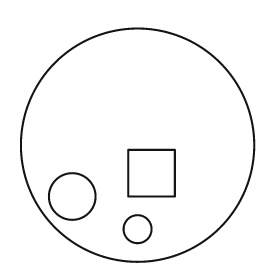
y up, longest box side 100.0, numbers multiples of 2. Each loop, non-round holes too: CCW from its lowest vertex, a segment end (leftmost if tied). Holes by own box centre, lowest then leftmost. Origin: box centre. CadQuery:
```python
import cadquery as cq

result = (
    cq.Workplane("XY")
    .moveTo(0.0, 0.0)
    .circle(50.0)
    .moveTo(0.0, -36.0)
    .circle(6.0)
    .moveTo(-28.0, -22.0)
    .circle(10.0)
    .moveTo(-4.0, -22.0)
    .lineTo(16.0, -22.0)
    .lineTo(16.0, -2.0)
    .lineTo(-4.0, -2.0)
    .close()
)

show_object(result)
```